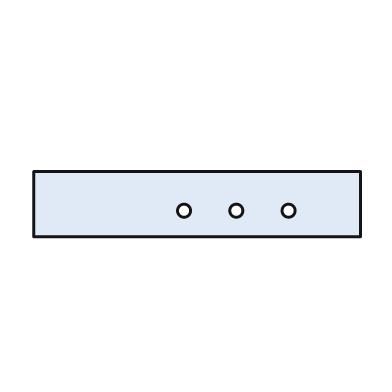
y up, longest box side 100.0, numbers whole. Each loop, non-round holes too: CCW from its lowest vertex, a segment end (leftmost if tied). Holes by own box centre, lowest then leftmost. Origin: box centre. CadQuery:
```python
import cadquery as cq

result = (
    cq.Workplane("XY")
    .moveTo(-50.0, -10.0)
    .lineTo(50.0, -10.0)
    .lineTo(50.0, 10.0)
    .lineTo(-50.0, 10.0)
    .close()
    .moveTo(-4.0, -2.0)
    .circle(2.0)
    .moveTo(12.0, -2.0)
    .circle(2.0)
    .moveTo(28.0, -2.0)
    .circle(2.0)
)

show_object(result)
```